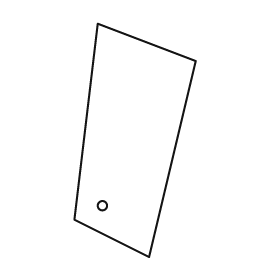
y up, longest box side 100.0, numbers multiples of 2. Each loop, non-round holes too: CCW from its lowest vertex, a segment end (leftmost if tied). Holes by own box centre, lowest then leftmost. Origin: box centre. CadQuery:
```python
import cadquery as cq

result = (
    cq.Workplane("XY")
    .moveTo(6.0, -50.0)
    .lineTo(26.0, 34.0)
    .lineTo(-16.0, 50.0)
    .lineTo(-26.0, -34.0)
    .close()
    .moveTo(-14.0, -28.0)
    .circle(2.0)
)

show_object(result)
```